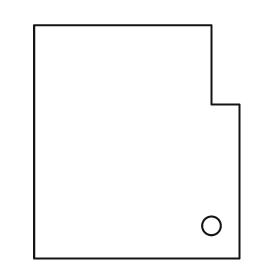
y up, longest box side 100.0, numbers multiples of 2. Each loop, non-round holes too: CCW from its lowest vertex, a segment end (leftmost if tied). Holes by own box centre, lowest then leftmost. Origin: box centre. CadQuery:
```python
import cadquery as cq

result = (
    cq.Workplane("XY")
    .moveTo(-44.0, -50.0)
    .lineTo(44.0, -50.0)
    .lineTo(44.0, 16.0)
    .lineTo(32.0, 16.0)
    .lineTo(32.0, 50.0)
    .lineTo(-44.0, 50.0)
    .close()
    .moveTo(32.0, -36.0)
    .circle(4.0)
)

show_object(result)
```